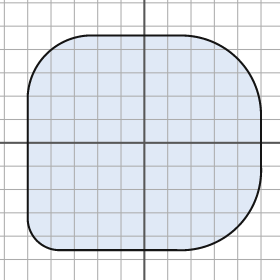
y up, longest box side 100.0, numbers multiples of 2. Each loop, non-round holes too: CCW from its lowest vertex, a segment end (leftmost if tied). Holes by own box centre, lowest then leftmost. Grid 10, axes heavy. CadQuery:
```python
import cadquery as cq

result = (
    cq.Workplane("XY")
    .moveTo(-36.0, -46.0)
    .lineTo(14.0, -46.0)
    .threePointArc((40.0, -36.0), (50.0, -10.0))
    .lineTo(50.0, 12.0)
    .threePointArc((40.0, 36.0), (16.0, 46.0))
    .lineTo(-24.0, 46.0)
    .threePointArc((-42.0, 38.0), (-50.0, 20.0))
    .lineTo(-50.0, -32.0)
    .threePointArc((-46.0, -42.0), (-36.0, -46.0))
    .close()
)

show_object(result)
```